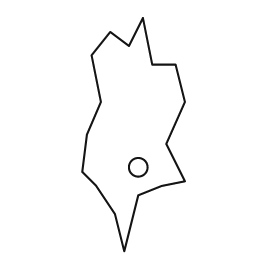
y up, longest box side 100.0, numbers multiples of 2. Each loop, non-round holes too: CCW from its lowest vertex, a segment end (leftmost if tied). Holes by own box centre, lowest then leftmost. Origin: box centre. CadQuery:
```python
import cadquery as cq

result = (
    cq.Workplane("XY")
    .moveTo(-4.0, -50.0)
    .lineTo(2.0, -26.0)
    .lineTo(12.0, -22.0)
    .lineTo(22.0, -20.0)
    .lineTo(14.0, -4.0)
    .lineTo(22.0, 14.0)
    .lineTo(18.0, 30.0)
    .lineTo(8.0, 30.0)
    .lineTo(4.0, 50.0)
    .lineTo(-2.0, 38.0)
    .lineTo(-10.0, 44.0)
    .lineTo(-18.0, 34.0)
    .lineTo(-14.0, 14.0)
    .lineTo(-20.0, 0.0)
    .lineTo(-22.0, -16.0)
    .lineTo(-16.0, -22.0)
    .lineTo(-8.0, -34.0)
    .close()
    .moveTo(2.0, -14.0)
    .circle(4.0)
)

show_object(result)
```